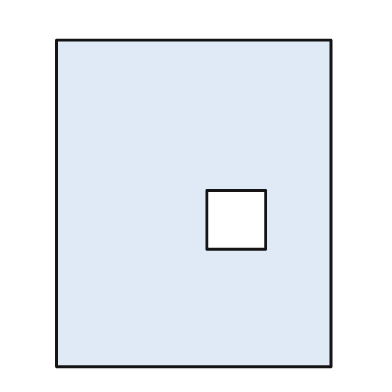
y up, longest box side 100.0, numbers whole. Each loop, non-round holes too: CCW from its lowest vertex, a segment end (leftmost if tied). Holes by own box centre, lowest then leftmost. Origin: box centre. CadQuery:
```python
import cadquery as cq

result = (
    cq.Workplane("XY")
    .moveTo(-42.0, -50.0)
    .lineTo(42.0, -50.0)
    .lineTo(42.0, 50.0)
    .lineTo(-42.0, 50.0)
    .close()
    .moveTo(4.0, -14.0)
    .lineTo(22.0, -14.0)
    .lineTo(22.0, 4.0)
    .lineTo(4.0, 4.0)
    .close()
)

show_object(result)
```